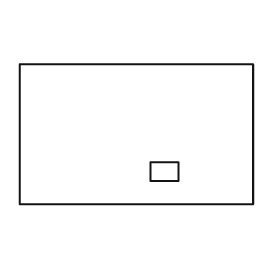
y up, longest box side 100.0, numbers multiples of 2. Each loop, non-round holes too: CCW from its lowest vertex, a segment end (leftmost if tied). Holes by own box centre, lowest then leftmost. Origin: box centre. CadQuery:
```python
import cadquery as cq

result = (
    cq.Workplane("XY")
    .moveTo(-50.0, -30.0)
    .lineTo(50.0, -30.0)
    .lineTo(50.0, 30.0)
    .lineTo(-50.0, 30.0)
    .close()
    .moveTo(6.0, -20.0)
    .lineTo(18.0, -20.0)
    .lineTo(18.0, -12.0)
    .lineTo(6.0, -12.0)
    .close()
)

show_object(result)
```